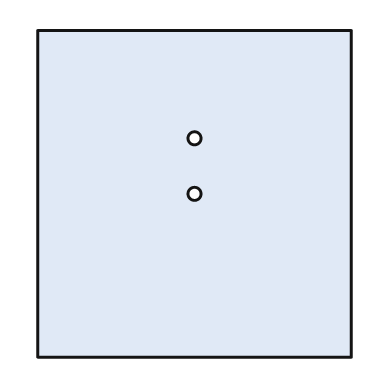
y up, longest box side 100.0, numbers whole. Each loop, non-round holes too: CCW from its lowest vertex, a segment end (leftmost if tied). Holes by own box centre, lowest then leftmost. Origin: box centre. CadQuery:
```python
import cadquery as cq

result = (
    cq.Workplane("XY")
    .moveTo(-48.0, -50.0)
    .lineTo(48.0, -50.0)
    .lineTo(48.0, 50.0)
    .lineTo(-48.0, 50.0)
    .close()
    .moveTo(0.0, 0.0)
    .circle(2.0)
    .moveTo(0.0, 17.0)
    .circle(2.0)
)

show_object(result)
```